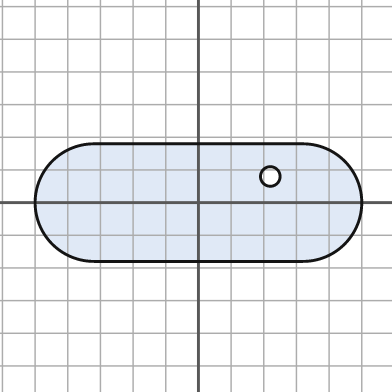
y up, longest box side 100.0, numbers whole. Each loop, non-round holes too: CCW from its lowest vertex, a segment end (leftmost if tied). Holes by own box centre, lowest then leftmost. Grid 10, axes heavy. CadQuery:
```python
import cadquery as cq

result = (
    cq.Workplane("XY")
    .moveTo(-32.0, -18.0)
    .lineTo(32.0, -18.0)
    .threePointArc((50.0, 0.0), (32.0, 18.0))
    .lineTo(-32.0, 18.0)
    .threePointArc((-50.0, 0.0), (-32.0, -18.0))
    .close()
    .moveTo(22.0, 8.0)
    .circle(3.0)
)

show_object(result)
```